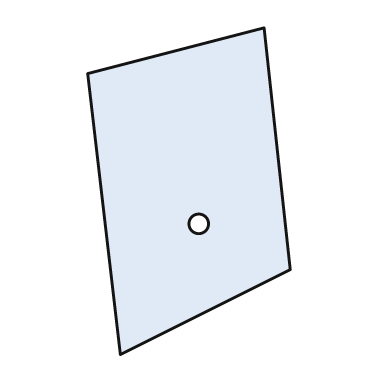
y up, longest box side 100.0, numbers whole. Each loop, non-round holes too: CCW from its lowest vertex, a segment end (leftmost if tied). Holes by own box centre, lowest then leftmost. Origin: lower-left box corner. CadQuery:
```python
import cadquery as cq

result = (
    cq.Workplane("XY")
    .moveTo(10.0, 0.0)
    .lineTo(62.0, 26.0)
    .lineTo(54.0, 100.0)
    .lineTo(0.0, 86.0)
    .close()
    .moveTo(34.0, 40.0)
    .circle(3.0)
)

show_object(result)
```